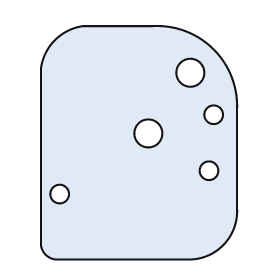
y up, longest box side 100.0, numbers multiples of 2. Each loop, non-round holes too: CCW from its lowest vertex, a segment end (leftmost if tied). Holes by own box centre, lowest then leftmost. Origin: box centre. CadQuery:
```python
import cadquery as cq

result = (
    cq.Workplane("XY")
    .moveTo(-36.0, -50.0)
    .lineTo(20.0, -50.0)
    .threePointArc((36.0, -44.0), (42.0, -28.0))
    .lineTo(42.0, 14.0)
    .threePointArc((32.0, 40.0), (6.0, 50.0))
    .lineTo(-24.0, 50.0)
    .threePointArc((-36.0, 44.0), (-42.0, 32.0))
    .lineTo(-42.0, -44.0)
    .threePointArc((-40.0, -48.0), (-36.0, -50.0))
    .close()
    .moveTo(-34.0, -22.0)
    .circle(4.0)
    .moveTo(30.0, -12.0)
    .circle(4.0)
    .moveTo(4.0, 4.0)
    .circle(6.0)
    .moveTo(32.0, 12.0)
    .circle(4.0)
    .moveTo(22.0, 30.0)
    .circle(6.0)
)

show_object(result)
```